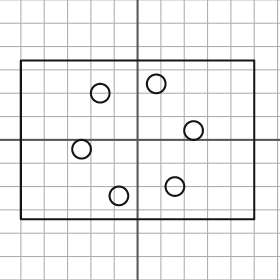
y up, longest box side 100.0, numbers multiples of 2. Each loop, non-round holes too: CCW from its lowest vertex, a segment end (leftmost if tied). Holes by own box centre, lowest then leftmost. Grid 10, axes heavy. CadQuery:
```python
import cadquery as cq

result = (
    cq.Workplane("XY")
    .moveTo(-50.0, -34.0)
    .lineTo(50.0, -34.0)
    .lineTo(50.0, 34.0)
    .lineTo(-50.0, 34.0)
    .close()
    .moveTo(-8.0, -24.0)
    .circle(4.0)
    .moveTo(16.0, -20.0)
    .circle(4.0)
    .moveTo(-24.0, -4.0)
    .circle(4.0)
    .moveTo(24.0, 4.0)
    .circle(4.0)
    .moveTo(-16.0, 20.0)
    .circle(4.0)
    .moveTo(8.0, 24.0)
    .circle(4.0)
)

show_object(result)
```